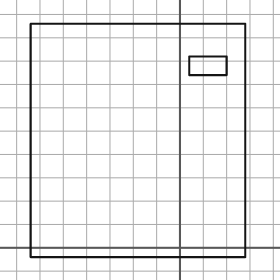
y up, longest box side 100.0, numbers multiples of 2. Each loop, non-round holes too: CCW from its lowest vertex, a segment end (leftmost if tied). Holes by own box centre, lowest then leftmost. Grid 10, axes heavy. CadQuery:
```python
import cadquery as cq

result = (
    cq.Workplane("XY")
    .moveTo(-64.0, -4.0)
    .lineTo(28.0, -4.0)
    .lineTo(28.0, 96.0)
    .lineTo(-64.0, 96.0)
    .close()
    .moveTo(4.0, 74.0)
    .lineTo(20.0, 74.0)
    .lineTo(20.0, 82.0)
    .lineTo(4.0, 82.0)
    .close()
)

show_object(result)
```